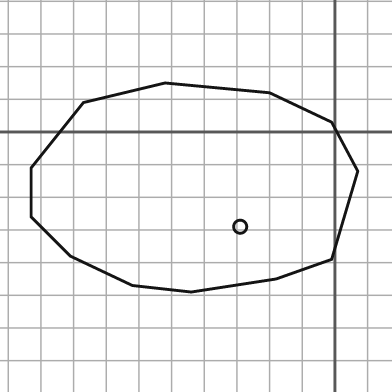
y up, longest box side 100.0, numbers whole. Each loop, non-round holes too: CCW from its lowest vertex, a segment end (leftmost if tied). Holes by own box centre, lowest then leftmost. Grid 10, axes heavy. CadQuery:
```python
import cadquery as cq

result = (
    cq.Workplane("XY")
    .moveTo(-44.0, -49.0)
    .lineTo(-18.0, -45.0)
    .lineTo(-1.0, -39.0)
    .lineTo(7.0, -12.0)
    .lineTo(-1.0, 3.0)
    .lineTo(-20.0, 12.0)
    .lineTo(-52.0, 15.0)
    .lineTo(-77.0, 9.0)
    .lineTo(-93.0, -11.0)
    .lineTo(-93.0, -26.0)
    .lineTo(-81.0, -38.0)
    .lineTo(-62.0, -47.0)
    .close()
    .moveTo(-29.0, -29.0)
    .circle(2.0)
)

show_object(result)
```